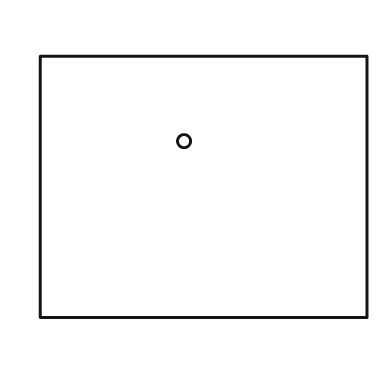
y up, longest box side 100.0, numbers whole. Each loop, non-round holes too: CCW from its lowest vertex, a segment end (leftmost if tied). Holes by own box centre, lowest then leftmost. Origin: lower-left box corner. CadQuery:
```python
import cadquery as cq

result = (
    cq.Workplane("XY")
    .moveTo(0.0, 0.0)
    .lineTo(100.0, 0.0)
    .lineTo(100.0, 80.0)
    .lineTo(0.0, 80.0)
    .close()
    .moveTo(44.0, 54.0)
    .circle(2.0)
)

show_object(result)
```